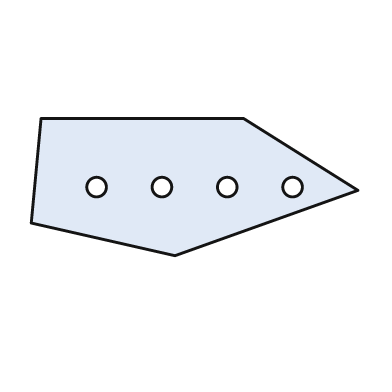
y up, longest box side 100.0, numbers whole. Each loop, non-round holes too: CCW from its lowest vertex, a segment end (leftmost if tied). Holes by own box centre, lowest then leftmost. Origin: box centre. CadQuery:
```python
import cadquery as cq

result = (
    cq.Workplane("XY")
    .moveTo(-6.0, -21.0)
    .lineTo(50.0, -1.0)
    .lineTo(15.0, 21.0)
    .lineTo(-47.0, 21.0)
    .lineTo(-50.0, -11.0)
    .close()
    .moveTo(-30.0, 0.0)
    .circle(3.0)
    .moveTo(-10.0, 0.0)
    .circle(3.0)
    .moveTo(10.0, 0.0)
    .circle(3.0)
    .moveTo(30.0, 0.0)
    .circle(3.0)
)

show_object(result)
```